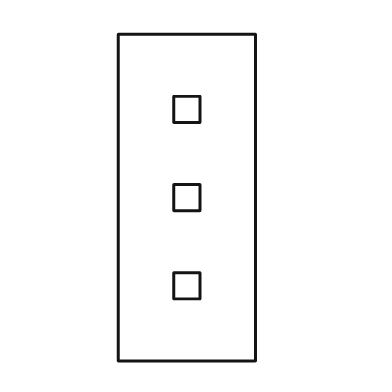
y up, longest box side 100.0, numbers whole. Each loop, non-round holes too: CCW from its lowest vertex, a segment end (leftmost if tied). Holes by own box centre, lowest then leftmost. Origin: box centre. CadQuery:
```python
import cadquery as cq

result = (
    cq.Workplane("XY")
    .moveTo(-21.0, -50.0)
    .lineTo(21.0, -50.0)
    .lineTo(21.0, 50.0)
    .lineTo(-21.0, 50.0)
    .close()
    .moveTo(-4.0, -31.0)
    .lineTo(4.0, -31.0)
    .lineTo(4.0, -23.0)
    .lineTo(-4.0, -23.0)
    .close()
    .moveTo(-4.0, -4.0)
    .lineTo(4.0, -4.0)
    .lineTo(4.0, 4.0)
    .lineTo(-4.0, 4.0)
    .close()
    .moveTo(-4.0, 23.0)
    .lineTo(4.0, 23.0)
    .lineTo(4.0, 31.0)
    .lineTo(-4.0, 31.0)
    .close()
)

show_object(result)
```